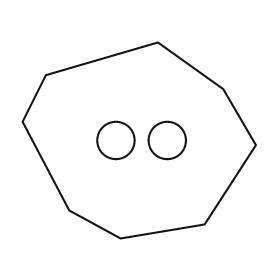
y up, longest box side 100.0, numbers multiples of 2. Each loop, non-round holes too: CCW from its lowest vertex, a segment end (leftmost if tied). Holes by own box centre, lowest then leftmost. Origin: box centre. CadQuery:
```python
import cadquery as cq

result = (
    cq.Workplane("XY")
    .moveTo(-8.0, -42.0)
    .lineTo(28.0, -36.0)
    .lineTo(50.0, -2.0)
    .lineTo(36.0, 22.0)
    .lineTo(8.0, 42.0)
    .lineTo(-40.0, 28.0)
    .lineTo(-50.0, 8.0)
    .lineTo(-30.0, -30.0)
    .close()
    .moveTo(-10.0, 0.0)
    .circle(8.0)
    .moveTo(12.0, 0.0)
    .circle(8.0)
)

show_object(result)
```